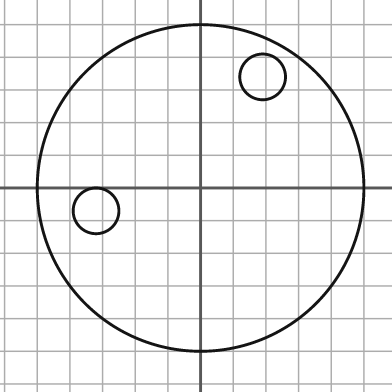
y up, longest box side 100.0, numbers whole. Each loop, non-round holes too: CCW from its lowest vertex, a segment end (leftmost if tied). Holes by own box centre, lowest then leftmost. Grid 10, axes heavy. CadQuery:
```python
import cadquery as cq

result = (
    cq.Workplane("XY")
    .moveTo(0.0, 0.0)
    .circle(50.0)
    .moveTo(-32.0, -7.0)
    .circle(7.0)
    .moveTo(19.0, 34.0)
    .circle(7.0)
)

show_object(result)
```